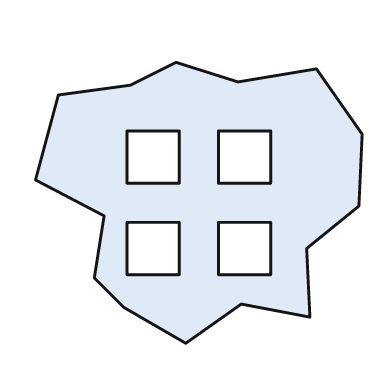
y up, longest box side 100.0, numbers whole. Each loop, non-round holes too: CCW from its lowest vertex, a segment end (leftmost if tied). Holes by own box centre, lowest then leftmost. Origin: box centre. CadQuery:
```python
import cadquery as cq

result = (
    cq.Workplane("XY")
    .moveTo(-4.0, -43.0)
    .lineTo(13.0, -31.0)
    .lineTo(34.0, -35.0)
    .lineTo(33.0, -14.0)
    .lineTo(49.0, -1.0)
    .lineTo(50.0, 21.0)
    .lineTo(36.0, 41.0)
    .lineTo(12.0, 37.0)
    .lineTo(-7.0, 43.0)
    .lineTo(-21.0, 36.0)
    .lineTo(-43.0, 33.0)
    .lineTo(-50.0, 7.0)
    .lineTo(-29.0, -4.0)
    .lineTo(-32.0, -23.0)
    .lineTo(-23.0, -32.0)
    .close()
    .moveTo(-22.0, -22.0)
    .lineTo(-6.0, -22.0)
    .lineTo(-6.0, -6.0)
    .lineTo(-22.0, -6.0)
    .close()
    .moveTo(6.0, -22.0)
    .lineTo(22.0, -22.0)
    .lineTo(22.0, -6.0)
    .lineTo(6.0, -6.0)
    .close()
    .moveTo(-22.0, 6.0)
    .lineTo(-6.0, 6.0)
    .lineTo(-6.0, 22.0)
    .lineTo(-22.0, 22.0)
    .close()
    .moveTo(6.0, 6.0)
    .lineTo(22.0, 6.0)
    .lineTo(22.0, 22.0)
    .lineTo(6.0, 22.0)
    .close()
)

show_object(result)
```